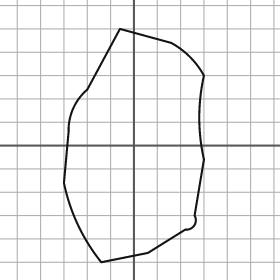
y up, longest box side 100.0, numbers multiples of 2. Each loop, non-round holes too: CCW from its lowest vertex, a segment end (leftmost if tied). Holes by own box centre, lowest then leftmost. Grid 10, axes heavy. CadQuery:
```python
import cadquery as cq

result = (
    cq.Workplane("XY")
    .moveTo(-14.0, -50.0)
    .lineTo(6.0, -46.0)
    .lineTo(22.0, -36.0)
    .threePointArc((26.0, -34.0), (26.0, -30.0))
    .lineTo(30.0, -6.0)
    .threePointArc((28.0, 12.0), (30.0, 30.0))
    .threePointArc((24.0, 38.0), (16.0, 44.0))
    .lineTo(-6.0, 50.0)
    .lineTo(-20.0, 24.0)
    .threePointArc((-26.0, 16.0), (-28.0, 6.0))
    .lineTo(-30.0, -16.0)
    .threePointArc((-24.0, -34.0), (-14.0, -50.0))
    .close()
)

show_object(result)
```